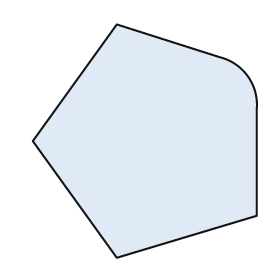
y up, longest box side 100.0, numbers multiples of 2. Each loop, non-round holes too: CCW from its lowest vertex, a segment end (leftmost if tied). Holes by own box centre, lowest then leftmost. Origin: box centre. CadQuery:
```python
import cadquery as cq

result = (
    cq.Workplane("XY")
    .moveTo(-12.0, -50.0)
    .lineTo(48.0, -32.0)
    .lineTo(48.0, 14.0)
    .threePointArc((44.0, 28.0), (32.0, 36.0))
    .lineTo(-12.0, 50.0)
    .lineTo(-48.0, 0.0)
    .close()
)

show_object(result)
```